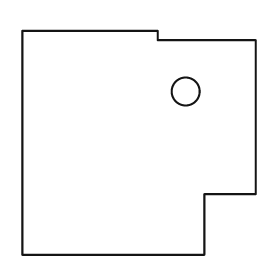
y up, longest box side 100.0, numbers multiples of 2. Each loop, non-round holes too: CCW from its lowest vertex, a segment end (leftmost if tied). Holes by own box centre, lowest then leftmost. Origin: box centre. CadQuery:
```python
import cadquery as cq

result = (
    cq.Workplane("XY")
    .moveTo(-50.0, -48.0)
    .lineTo(28.0, -48.0)
    .lineTo(28.0, -22.0)
    .lineTo(50.0, -22.0)
    .lineTo(50.0, 44.0)
    .lineTo(8.0, 44.0)
    .lineTo(8.0, 48.0)
    .lineTo(-50.0, 48.0)
    .close()
    .moveTo(20.0, 22.0)
    .circle(6.0)
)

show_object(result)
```